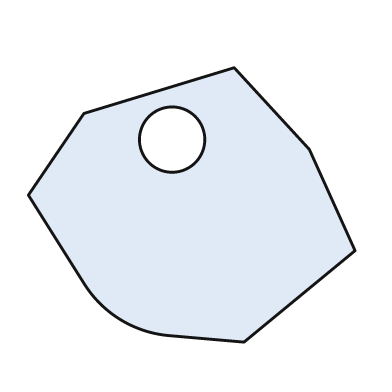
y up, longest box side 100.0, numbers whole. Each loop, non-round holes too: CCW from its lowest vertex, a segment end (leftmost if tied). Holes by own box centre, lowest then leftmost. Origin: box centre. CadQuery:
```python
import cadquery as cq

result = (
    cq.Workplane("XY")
    .moveTo(16.0, -42.0)
    .lineTo(50.0, -14.0)
    .lineTo(36.0, 17.0)
    .lineTo(13.0, 42.0)
    .lineTo(-33.0, 28.0)
    .lineTo(-50.0, 3.0)
    .lineTo(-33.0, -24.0)
    .threePointArc((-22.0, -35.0), (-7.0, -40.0))
    .close()
    .moveTo(-6.0, 20.0)
    .circle(10.0)
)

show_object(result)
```